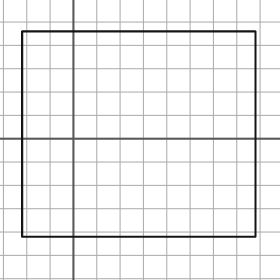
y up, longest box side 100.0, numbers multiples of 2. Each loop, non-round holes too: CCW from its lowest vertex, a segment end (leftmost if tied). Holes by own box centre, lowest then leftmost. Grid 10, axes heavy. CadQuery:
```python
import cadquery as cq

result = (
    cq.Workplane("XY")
    .moveTo(-22.0, -42.0)
    .lineTo(78.0, -42.0)
    .lineTo(78.0, 46.0)
    .lineTo(-22.0, 46.0)
    .close()
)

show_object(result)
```